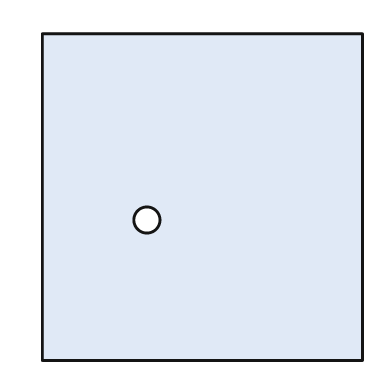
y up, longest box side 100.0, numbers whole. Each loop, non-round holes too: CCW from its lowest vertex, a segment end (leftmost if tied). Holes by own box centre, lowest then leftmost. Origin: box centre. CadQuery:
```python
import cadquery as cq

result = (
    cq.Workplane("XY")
    .moveTo(-49.0, -50.0)
    .lineTo(49.0, -50.0)
    .lineTo(49.0, 50.0)
    .lineTo(-49.0, 50.0)
    .close()
    .moveTo(-17.0, -7.0)
    .circle(4.0)
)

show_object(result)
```